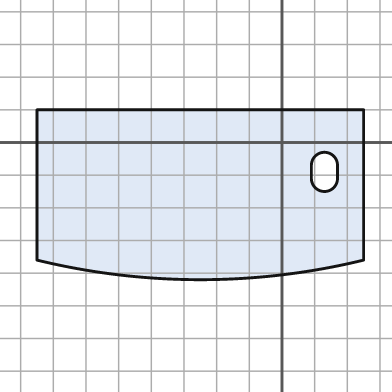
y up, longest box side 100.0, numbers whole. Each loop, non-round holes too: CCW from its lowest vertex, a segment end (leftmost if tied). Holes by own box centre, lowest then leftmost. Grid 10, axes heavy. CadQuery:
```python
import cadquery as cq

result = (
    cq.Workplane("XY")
    .moveTo(-75.0, -36.0)
    .threePointArc((-25.0, -42.0), (25.0, -36.0))
    .lineTo(25.0, 10.0)
    .lineTo(-75.0, 10.0)
    .close()
    .moveTo(9.0, -11.0)
    .threePointArc((13.0, -15.0), (17.0, -11.0))
    .lineTo(17.0, -7.0)
    .threePointArc((13.0, -3.0), (9.0, -7.0))
    .close()
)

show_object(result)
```